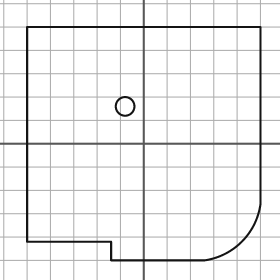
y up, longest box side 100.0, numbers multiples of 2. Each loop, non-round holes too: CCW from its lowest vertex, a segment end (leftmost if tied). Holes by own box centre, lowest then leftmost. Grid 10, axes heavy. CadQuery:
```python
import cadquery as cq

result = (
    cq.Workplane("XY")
    .moveTo(-14.0, -50.0)
    .lineTo(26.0, -50.0)
    .threePointArc((42.0, -42.0), (50.0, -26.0))
    .lineTo(50.0, 50.0)
    .lineTo(-50.0, 50.0)
    .lineTo(-50.0, -42.0)
    .lineTo(-14.0, -42.0)
    .close()
    .moveTo(-8.0, 16.0)
    .circle(4.0)
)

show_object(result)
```